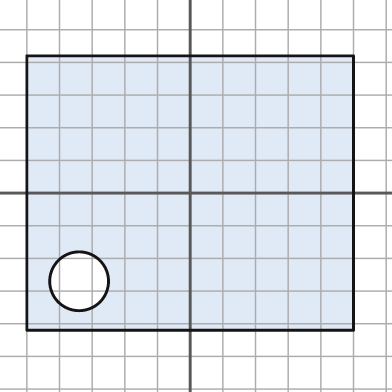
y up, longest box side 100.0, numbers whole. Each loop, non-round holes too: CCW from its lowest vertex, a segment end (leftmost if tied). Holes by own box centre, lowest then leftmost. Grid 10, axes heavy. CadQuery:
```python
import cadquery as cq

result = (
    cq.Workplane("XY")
    .moveTo(-50.0, -42.0)
    .lineTo(50.0, -42.0)
    .lineTo(50.0, 42.0)
    .lineTo(-50.0, 42.0)
    .close()
    .moveTo(-34.0, -27.0)
    .circle(9.0)
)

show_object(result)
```